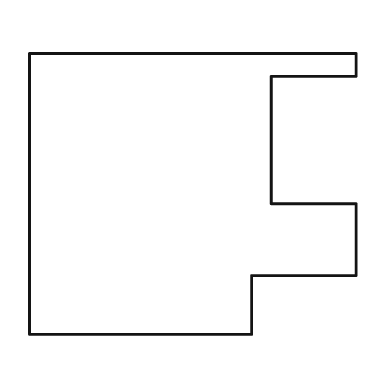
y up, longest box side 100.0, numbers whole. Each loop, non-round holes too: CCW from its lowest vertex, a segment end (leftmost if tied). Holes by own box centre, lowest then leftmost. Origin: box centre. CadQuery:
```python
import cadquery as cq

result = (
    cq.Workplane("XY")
    .moveTo(-50.0, -43.0)
    .lineTo(18.0, -43.0)
    .lineTo(18.0, -25.0)
    .lineTo(50.0, -25.0)
    .lineTo(50.0, -3.0)
    .lineTo(24.0, -3.0)
    .lineTo(24.0, 36.0)
    .lineTo(50.0, 36.0)
    .lineTo(50.0, 43.0)
    .lineTo(-50.0, 43.0)
    .close()
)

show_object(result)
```